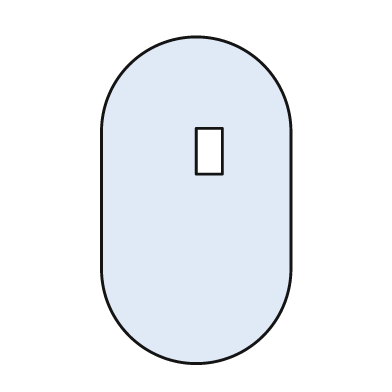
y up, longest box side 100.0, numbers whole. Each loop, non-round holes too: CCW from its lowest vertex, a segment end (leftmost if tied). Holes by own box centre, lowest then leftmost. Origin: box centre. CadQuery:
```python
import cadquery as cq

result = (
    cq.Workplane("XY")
    .moveTo(-29.0, -21.0)
    .threePointArc((0.0, -50.0), (29.0, -21.0))
    .lineTo(29.0, 21.0)
    .threePointArc((0.0, 50.0), (-29.0, 21.0))
    .close()
    .moveTo(0.0, 8.0)
    .lineTo(8.0, 8.0)
    .lineTo(8.0, 22.0)
    .lineTo(0.0, 22.0)
    .close()
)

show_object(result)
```